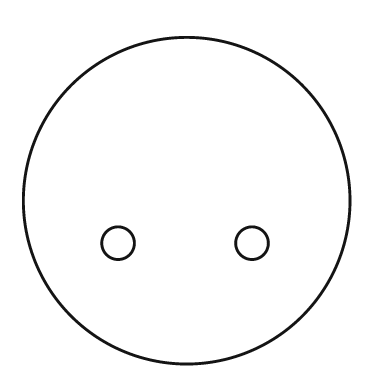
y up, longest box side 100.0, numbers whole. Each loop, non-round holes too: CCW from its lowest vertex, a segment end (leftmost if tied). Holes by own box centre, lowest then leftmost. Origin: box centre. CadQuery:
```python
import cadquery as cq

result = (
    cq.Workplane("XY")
    .moveTo(0.0, 0.0)
    .circle(50.0)
    .moveTo(-21.0, -13.0)
    .circle(5.0)
    .moveTo(20.0, -13.0)
    .circle(5.0)
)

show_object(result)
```